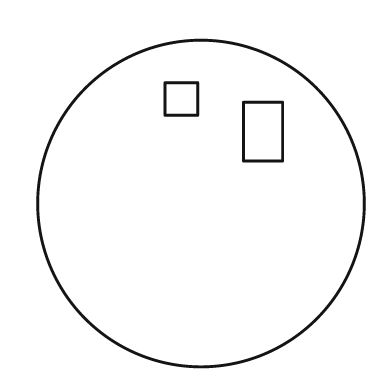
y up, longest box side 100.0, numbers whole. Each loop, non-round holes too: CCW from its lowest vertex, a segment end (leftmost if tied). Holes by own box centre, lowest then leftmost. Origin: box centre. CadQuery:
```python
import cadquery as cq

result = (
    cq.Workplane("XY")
    .moveTo(0.0, 0.0)
    .circle(50.0)
    .moveTo(13.0, 13.0)
    .lineTo(25.0, 13.0)
    .lineTo(25.0, 31.0)
    .lineTo(13.0, 31.0)
    .close()
    .moveTo(-11.0, 27.0)
    .lineTo(-1.0, 27.0)
    .lineTo(-1.0, 37.0)
    .lineTo(-11.0, 37.0)
    .close()
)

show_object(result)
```